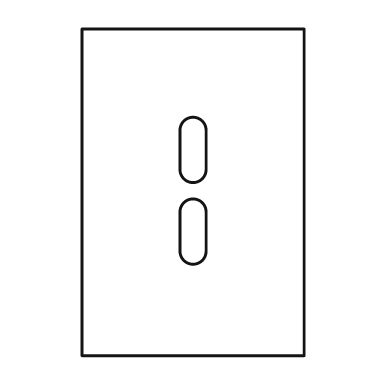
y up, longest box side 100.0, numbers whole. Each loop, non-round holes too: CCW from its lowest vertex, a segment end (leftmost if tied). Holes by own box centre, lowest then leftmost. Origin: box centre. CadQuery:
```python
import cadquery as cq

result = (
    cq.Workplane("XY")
    .moveTo(-34.0, -50.0)
    .lineTo(34.0, -50.0)
    .lineTo(34.0, 50.0)
    .lineTo(-34.0, 50.0)
    .close()
    .moveTo(-4.0, -18.0)
    .threePointArc((0.0, -22.0), (4.0, -18.0))
    .lineTo(4.0, -6.0)
    .threePointArc((0.0, -2.0), (-4.0, -6.0))
    .close()
    .moveTo(-4.0, 7.0)
    .threePointArc((0.0, 3.0), (4.0, 7.0))
    .lineTo(4.0, 19.0)
    .threePointArc((0.0, 23.0), (-4.0, 19.0))
    .close()
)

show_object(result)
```